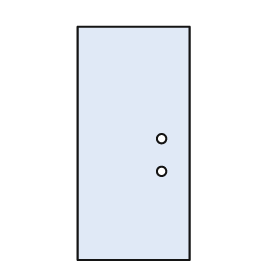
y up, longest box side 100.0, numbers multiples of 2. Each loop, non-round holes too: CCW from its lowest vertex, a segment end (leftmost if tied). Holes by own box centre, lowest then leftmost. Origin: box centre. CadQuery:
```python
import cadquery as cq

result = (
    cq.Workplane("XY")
    .moveTo(-24.0, -50.0)
    .lineTo(24.0, -50.0)
    .lineTo(24.0, 50.0)
    .lineTo(-24.0, 50.0)
    .close()
    .moveTo(12.0, -12.0)
    .circle(2.0)
    .moveTo(12.0, 2.0)
    .circle(2.0)
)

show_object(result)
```